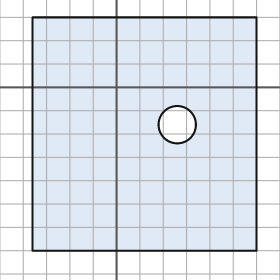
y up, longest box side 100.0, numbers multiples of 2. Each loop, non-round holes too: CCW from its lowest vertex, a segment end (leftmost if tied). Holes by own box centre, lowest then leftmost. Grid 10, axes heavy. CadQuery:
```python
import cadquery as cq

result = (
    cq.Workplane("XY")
    .moveTo(-36.0, -70.0)
    .lineTo(60.0, -70.0)
    .lineTo(60.0, 30.0)
    .lineTo(-36.0, 30.0)
    .close()
    .moveTo(26.0, -16.0)
    .circle(8.0)
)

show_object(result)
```